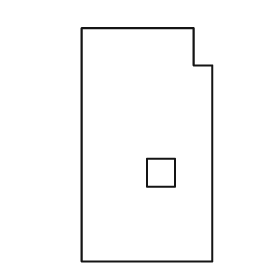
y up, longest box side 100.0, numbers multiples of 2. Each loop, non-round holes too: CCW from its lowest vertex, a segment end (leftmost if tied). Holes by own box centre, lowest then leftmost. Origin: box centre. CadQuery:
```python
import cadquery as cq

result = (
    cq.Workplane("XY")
    .moveTo(-28.0, -50.0)
    .lineTo(28.0, -50.0)
    .lineTo(28.0, 34.0)
    .lineTo(20.0, 34.0)
    .lineTo(20.0, 50.0)
    .lineTo(-28.0, 50.0)
    .close()
    .moveTo(0.0, -18.0)
    .lineTo(12.0, -18.0)
    .lineTo(12.0, -6.0)
    .lineTo(0.0, -6.0)
    .close()
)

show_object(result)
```